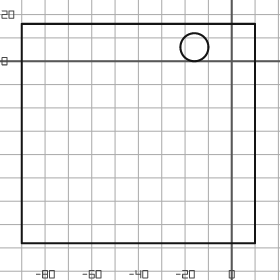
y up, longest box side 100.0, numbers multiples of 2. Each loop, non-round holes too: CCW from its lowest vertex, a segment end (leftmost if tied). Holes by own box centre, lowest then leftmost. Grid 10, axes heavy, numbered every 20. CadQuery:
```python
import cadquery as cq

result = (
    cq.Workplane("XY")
    .moveTo(-90.0, -78.0)
    .lineTo(10.0, -78.0)
    .lineTo(10.0, 16.0)
    .lineTo(-90.0, 16.0)
    .close()
    .moveTo(-16.0, 6.0)
    .circle(6.0)
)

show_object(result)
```